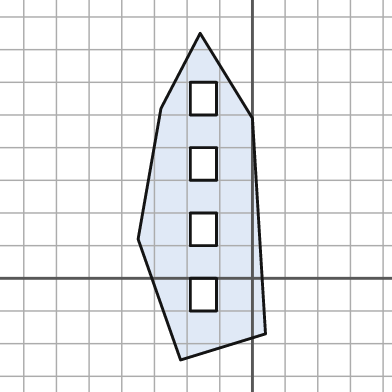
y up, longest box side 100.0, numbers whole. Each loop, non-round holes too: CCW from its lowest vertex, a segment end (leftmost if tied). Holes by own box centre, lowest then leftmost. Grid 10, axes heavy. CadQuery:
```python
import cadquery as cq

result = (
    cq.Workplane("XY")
    .moveTo(-22.0, -25.0)
    .lineTo(4.0, -17.0)
    .lineTo(0.0, 49.0)
    .lineTo(-16.0, 75.0)
    .lineTo(-28.0, 52.0)
    .lineTo(-35.0, 12.0)
    .close()
    .moveTo(-19.0, -10.0)
    .lineTo(-11.0, -10.0)
    .lineTo(-11.0, 0.0)
    .lineTo(-19.0, 0.0)
    .close()
    .moveTo(-19.0, 10.0)
    .lineTo(-11.0, 10.0)
    .lineTo(-11.0, 20.0)
    .lineTo(-19.0, 20.0)
    .close()
    .moveTo(-19.0, 30.0)
    .lineTo(-11.0, 30.0)
    .lineTo(-11.0, 40.0)
    .lineTo(-19.0, 40.0)
    .close()
    .moveTo(-19.0, 50.0)
    .lineTo(-11.0, 50.0)
    .lineTo(-11.0, 60.0)
    .lineTo(-19.0, 60.0)
    .close()
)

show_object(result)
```